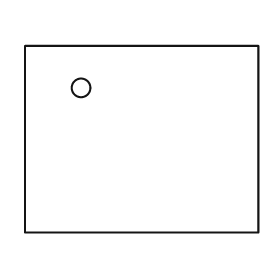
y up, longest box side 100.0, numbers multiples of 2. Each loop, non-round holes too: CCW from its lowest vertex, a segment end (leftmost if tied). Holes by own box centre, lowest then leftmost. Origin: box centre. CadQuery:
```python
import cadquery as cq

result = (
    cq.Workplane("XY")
    .moveTo(-50.0, -40.0)
    .lineTo(50.0, -40.0)
    .lineTo(50.0, 40.0)
    .lineTo(-50.0, 40.0)
    .close()
    .moveTo(-26.0, 22.0)
    .circle(4.0)
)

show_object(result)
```